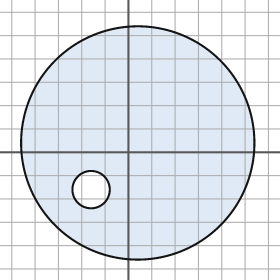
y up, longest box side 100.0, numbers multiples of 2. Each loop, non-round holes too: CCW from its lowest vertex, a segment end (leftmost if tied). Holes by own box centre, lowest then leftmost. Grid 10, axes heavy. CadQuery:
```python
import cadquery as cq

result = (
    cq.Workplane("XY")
    .moveTo(4.0, 4.0)
    .circle(50.0)
    .moveTo(-16.0, -16.0)
    .circle(8.0)
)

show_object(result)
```